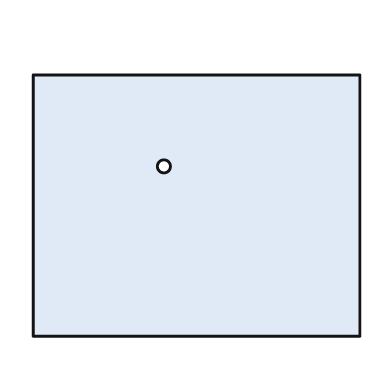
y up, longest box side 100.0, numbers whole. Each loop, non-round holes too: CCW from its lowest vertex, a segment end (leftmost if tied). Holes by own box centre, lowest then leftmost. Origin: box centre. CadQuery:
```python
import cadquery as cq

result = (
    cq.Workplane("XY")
    .moveTo(-50.0, -40.0)
    .lineTo(50.0, -40.0)
    .lineTo(50.0, 40.0)
    .lineTo(-50.0, 40.0)
    .close()
    .moveTo(-10.0, 12.0)
    .circle(2.0)
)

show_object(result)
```